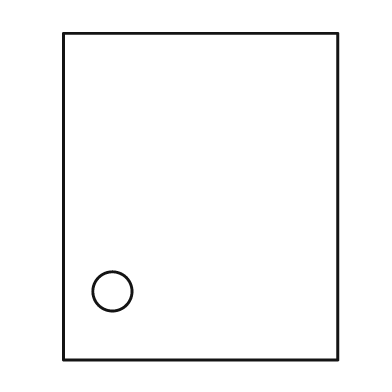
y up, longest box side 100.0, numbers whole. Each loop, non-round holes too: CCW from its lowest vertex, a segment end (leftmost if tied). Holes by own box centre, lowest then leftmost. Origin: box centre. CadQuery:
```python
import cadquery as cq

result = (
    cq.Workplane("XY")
    .moveTo(-42.0, -50.0)
    .lineTo(42.0, -50.0)
    .lineTo(42.0, 50.0)
    .lineTo(-42.0, 50.0)
    .close()
    .moveTo(-27.0, -29.0)
    .circle(6.0)
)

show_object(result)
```